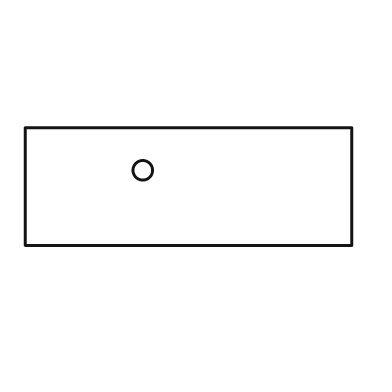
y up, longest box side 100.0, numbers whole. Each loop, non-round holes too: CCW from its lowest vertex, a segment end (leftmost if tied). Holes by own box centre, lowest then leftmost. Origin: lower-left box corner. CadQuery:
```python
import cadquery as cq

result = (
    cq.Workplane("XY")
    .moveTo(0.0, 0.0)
    .lineTo(100.0, 0.0)
    .lineTo(100.0, 36.0)
    .lineTo(0.0, 36.0)
    .close()
    .moveTo(36.0, 23.0)
    .circle(3.0)
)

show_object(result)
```